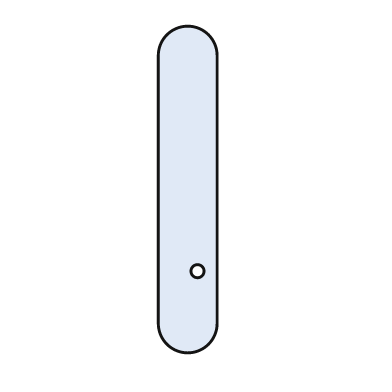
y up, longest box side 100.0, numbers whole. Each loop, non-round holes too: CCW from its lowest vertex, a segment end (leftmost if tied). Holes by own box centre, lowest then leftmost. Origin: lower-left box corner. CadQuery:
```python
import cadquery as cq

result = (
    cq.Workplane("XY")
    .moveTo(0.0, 9.0)
    .threePointArc((9.0, 0.0), (18.0, 9.0))
    .lineTo(18.0, 91.0)
    .threePointArc((9.0, 100.0), (0.0, 91.0))
    .close()
    .moveTo(12.0, 25.0)
    .circle(2.0)
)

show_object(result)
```